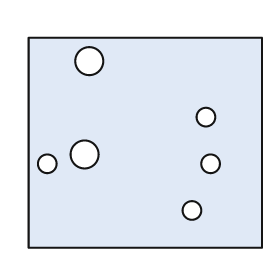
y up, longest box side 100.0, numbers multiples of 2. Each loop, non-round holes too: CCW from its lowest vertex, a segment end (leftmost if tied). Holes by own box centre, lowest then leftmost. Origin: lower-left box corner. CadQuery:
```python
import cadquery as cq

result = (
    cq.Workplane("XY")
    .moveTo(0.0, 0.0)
    .lineTo(100.0, 0.0)
    .lineTo(100.0, 90.0)
    .lineTo(0.0, 90.0)
    .close()
    .moveTo(70.0, 16.0)
    .circle(4.0)
    .moveTo(8.0, 36.0)
    .circle(4.0)
    .moveTo(78.0, 36.0)
    .circle(4.0)
    .moveTo(24.0, 40.0)
    .circle(6.0)
    .moveTo(76.0, 56.0)
    .circle(4.0)
    .moveTo(26.0, 80.0)
    .circle(6.0)
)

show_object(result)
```